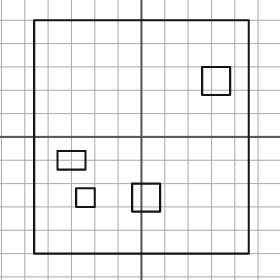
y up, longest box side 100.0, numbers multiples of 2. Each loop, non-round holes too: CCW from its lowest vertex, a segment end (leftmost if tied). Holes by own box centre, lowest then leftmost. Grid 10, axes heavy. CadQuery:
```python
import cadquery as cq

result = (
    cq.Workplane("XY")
    .moveTo(-46.0, -50.0)
    .lineTo(46.0, -50.0)
    .lineTo(46.0, 50.0)
    .lineTo(-46.0, 50.0)
    .close()
    .moveTo(-28.0, -30.0)
    .lineTo(-20.0, -30.0)
    .lineTo(-20.0, -22.0)
    .lineTo(-28.0, -22.0)
    .close()
    .moveTo(-4.0, -32.0)
    .lineTo(8.0, -32.0)
    .lineTo(8.0, -20.0)
    .lineTo(-4.0, -20.0)
    .close()
    .moveTo(-36.0, -14.0)
    .lineTo(-24.0, -14.0)
    .lineTo(-24.0, -6.0)
    .lineTo(-36.0, -6.0)
    .close()
    .moveTo(26.0, 18.0)
    .lineTo(38.0, 18.0)
    .lineTo(38.0, 30.0)
    .lineTo(26.0, 30.0)
    .close()
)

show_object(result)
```